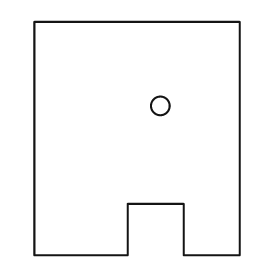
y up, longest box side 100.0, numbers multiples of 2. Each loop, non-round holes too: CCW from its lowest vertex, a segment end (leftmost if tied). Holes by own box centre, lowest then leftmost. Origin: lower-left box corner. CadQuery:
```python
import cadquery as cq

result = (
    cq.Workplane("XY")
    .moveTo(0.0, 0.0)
    .lineTo(40.0, 0.0)
    .lineTo(40.0, 22.0)
    .lineTo(64.0, 22.0)
    .lineTo(64.0, 0.0)
    .lineTo(88.0, 0.0)
    .lineTo(88.0, 100.0)
    .lineTo(0.0, 100.0)
    .close()
    .moveTo(54.0, 64.0)
    .circle(4.0)
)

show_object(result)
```